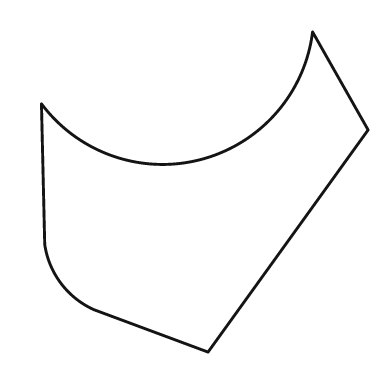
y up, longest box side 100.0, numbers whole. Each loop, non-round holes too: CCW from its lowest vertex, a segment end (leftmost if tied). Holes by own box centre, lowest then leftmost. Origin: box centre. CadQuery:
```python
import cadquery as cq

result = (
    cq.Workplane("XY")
    .moveTo(1.0, -49.0)
    .lineTo(50.0, 19.0)
    .lineTo(33.0, 49.0)
    .threePointArc((-1.0, 10.0), (-50.0, 27.0))
    .lineTo(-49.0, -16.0)
    .threePointArc((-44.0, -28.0), (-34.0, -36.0))
    .close()
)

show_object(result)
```